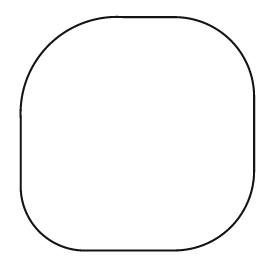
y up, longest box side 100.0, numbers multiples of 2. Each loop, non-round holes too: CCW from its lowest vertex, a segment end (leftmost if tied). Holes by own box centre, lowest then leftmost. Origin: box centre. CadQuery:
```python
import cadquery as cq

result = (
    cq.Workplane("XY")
    .moveTo(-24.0, -50.0)
    .lineTo(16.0, -50.0)
    .threePointArc((40.0, -40.0), (50.0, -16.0))
    .lineTo(50.0, 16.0)
    .threePointArc((40.0, 40.0), (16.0, 50.0))
    .lineTo(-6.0, 50.0)
    .threePointArc((-38.0, 38.0), (-50.0, 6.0))
    .lineTo(-50.0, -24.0)
    .threePointArc((-42.0, -42.0), (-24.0, -50.0))
    .close()
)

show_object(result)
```